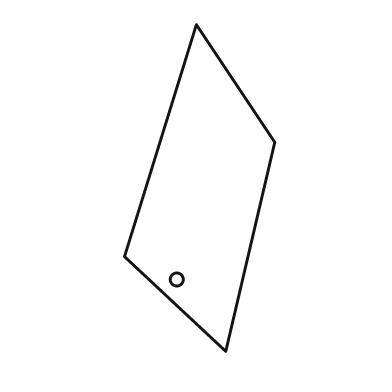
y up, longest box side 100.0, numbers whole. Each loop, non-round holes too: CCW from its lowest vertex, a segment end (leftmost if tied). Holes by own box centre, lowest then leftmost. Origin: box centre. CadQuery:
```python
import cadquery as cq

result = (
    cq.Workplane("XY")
    .moveTo(8.0, -50.0)
    .lineTo(23.0, 14.0)
    .lineTo(-1.0, 50.0)
    .lineTo(-23.0, -21.0)
    .close()
    .moveTo(-7.0, -28.0)
    .circle(2.0)
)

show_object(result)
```